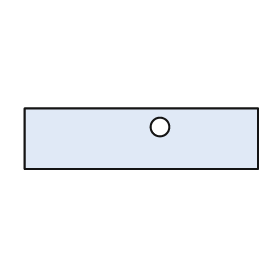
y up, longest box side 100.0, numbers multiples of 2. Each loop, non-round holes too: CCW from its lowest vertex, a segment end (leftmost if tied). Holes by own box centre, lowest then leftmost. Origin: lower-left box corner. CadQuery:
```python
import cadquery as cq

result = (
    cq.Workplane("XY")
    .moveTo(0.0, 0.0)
    .lineTo(100.0, 0.0)
    .lineTo(100.0, 26.0)
    .lineTo(0.0, 26.0)
    .close()
    .moveTo(58.0, 18.0)
    .circle(4.0)
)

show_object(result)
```